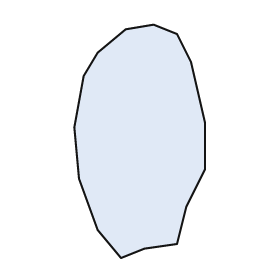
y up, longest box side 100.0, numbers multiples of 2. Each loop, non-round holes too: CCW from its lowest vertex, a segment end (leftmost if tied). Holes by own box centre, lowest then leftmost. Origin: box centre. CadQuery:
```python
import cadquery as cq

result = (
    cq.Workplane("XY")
    .moveTo(-8.0, -50.0)
    .lineTo(2.0, -46.0)
    .lineTo(16.0, -44.0)
    .lineTo(20.0, -28.0)
    .lineTo(28.0, -12.0)
    .lineTo(28.0, 8.0)
    .lineTo(22.0, 34.0)
    .lineTo(16.0, 46.0)
    .lineTo(6.0, 50.0)
    .lineTo(-6.0, 48.0)
    .lineTo(-18.0, 38.0)
    .lineTo(-24.0, 28.0)
    .lineTo(-28.0, 6.0)
    .lineTo(-26.0, -16.0)
    .lineTo(-18.0, -38.0)
    .close()
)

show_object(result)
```